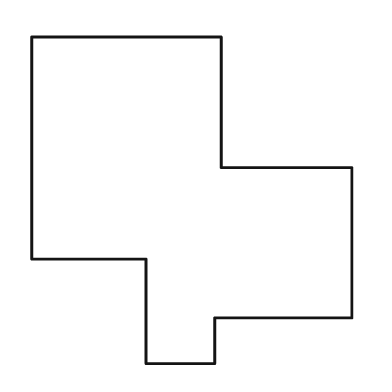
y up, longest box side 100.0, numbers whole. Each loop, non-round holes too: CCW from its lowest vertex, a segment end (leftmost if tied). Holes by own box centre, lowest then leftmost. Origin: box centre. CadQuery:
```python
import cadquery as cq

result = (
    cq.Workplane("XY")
    .moveTo(-14.0, -50.0)
    .lineTo(7.0, -50.0)
    .lineTo(7.0, -36.0)
    .lineTo(49.0, -36.0)
    .lineTo(49.0, 10.0)
    .lineTo(9.0, 10.0)
    .lineTo(9.0, 50.0)
    .lineTo(-49.0, 50.0)
    .lineTo(-49.0, -18.0)
    .lineTo(-14.0, -18.0)
    .close()
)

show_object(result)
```